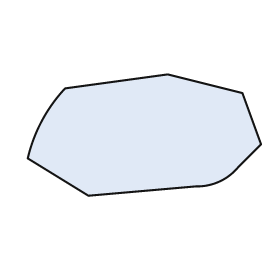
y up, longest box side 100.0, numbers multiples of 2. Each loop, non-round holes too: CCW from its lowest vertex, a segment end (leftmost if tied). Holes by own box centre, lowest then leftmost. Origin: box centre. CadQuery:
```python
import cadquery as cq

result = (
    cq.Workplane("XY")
    .moveTo(-24.0, -26.0)
    .lineTo(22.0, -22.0)
    .threePointArc((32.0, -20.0), (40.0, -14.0))
    .lineTo(50.0, -4.0)
    .lineTo(42.0, 18.0)
    .lineTo(10.0, 26.0)
    .lineTo(-34.0, 20.0)
    .threePointArc((-44.0, 6.0), (-50.0, -10.0))
    .close()
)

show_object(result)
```